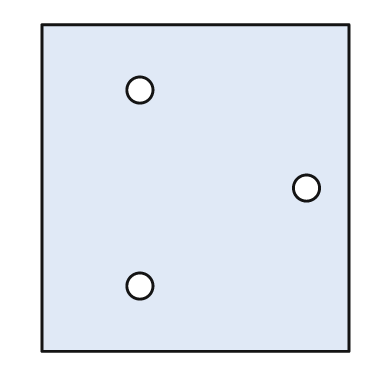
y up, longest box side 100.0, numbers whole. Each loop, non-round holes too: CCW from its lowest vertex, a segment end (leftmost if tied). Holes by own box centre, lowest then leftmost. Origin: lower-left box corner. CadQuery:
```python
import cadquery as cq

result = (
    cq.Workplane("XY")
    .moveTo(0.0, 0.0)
    .lineTo(94.0, 0.0)
    .lineTo(94.0, 100.0)
    .lineTo(0.0, 100.0)
    .close()
    .moveTo(30.0, 20.0)
    .circle(4.0)
    .moveTo(81.0, 50.0)
    .circle(4.0)
    .moveTo(30.0, 80.0)
    .circle(4.0)
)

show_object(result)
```